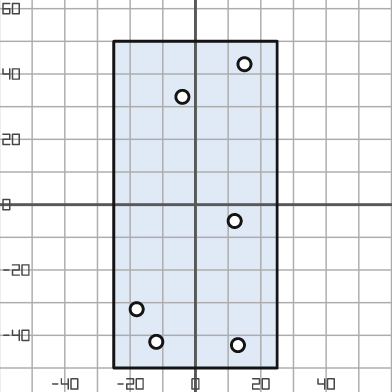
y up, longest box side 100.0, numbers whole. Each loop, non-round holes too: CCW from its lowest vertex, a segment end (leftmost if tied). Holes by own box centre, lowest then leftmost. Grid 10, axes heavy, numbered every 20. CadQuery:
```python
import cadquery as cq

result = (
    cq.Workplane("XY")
    .moveTo(-25.0, -50.0)
    .lineTo(25.0, -50.0)
    .lineTo(25.0, 50.0)
    .lineTo(-25.0, 50.0)
    .close()
    .moveTo(13.0, -43.0)
    .circle(2.0)
    .moveTo(-12.0, -42.0)
    .circle(2.0)
    .moveTo(-18.0, -32.0)
    .circle(2.0)
    .moveTo(12.0, -5.0)
    .circle(2.0)
    .moveTo(-4.0, 33.0)
    .circle(2.0)
    .moveTo(15.0, 43.0)
    .circle(2.0)
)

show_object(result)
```